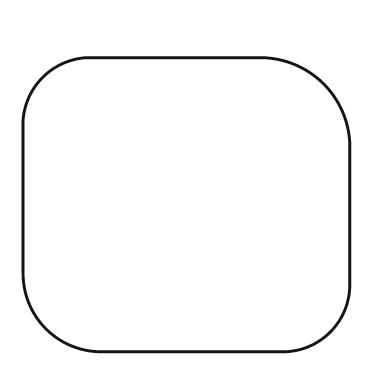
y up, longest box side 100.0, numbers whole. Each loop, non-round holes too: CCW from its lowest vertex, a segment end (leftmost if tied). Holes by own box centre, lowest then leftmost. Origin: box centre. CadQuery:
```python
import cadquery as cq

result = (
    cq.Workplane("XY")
    .moveTo(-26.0, -45.0)
    .lineTo(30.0, -45.0)
    .threePointArc((44.0, -39.0), (50.0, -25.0))
    .lineTo(50.0, 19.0)
    .threePointArc((42.0, 37.0), (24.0, 45.0))
    .lineTo(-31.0, 45.0)
    .threePointArc((-44.0, 39.0), (-50.0, 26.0))
    .lineTo(-50.0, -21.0)
    .threePointArc((-43.0, -38.0), (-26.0, -45.0))
    .close()
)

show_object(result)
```